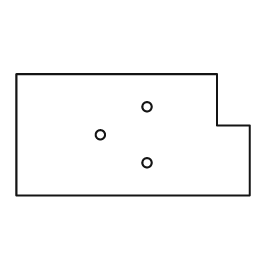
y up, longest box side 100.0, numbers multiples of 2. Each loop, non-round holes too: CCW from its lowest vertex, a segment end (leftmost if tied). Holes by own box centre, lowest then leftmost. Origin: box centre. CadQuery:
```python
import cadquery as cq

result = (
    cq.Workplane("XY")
    .moveTo(-50.0, -26.0)
    .lineTo(50.0, -26.0)
    .lineTo(50.0, 4.0)
    .lineTo(36.0, 4.0)
    .lineTo(36.0, 26.0)
    .lineTo(-50.0, 26.0)
    .close()
    .moveTo(6.0, -12.0)
    .circle(2.0)
    .moveTo(-14.0, 0.0)
    .circle(2.0)
    .moveTo(6.0, 12.0)
    .circle(2.0)
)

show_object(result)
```